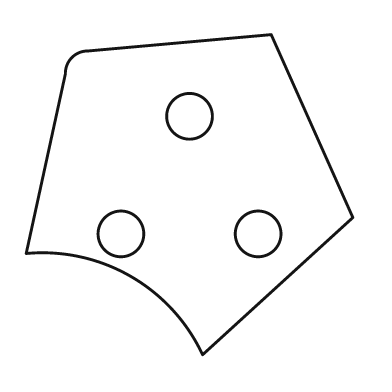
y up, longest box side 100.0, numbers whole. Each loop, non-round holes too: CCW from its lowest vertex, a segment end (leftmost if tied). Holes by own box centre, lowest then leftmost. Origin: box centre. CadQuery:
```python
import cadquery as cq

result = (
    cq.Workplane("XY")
    .moveTo(4.0, -49.0)
    .lineTo(50.0, -7.0)
    .lineTo(25.0, 49.0)
    .lineTo(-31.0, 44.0)
    .threePointArc((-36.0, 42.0), (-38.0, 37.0))
    .lineTo(-50.0, -18.0)
    .threePointArc((-18.0, -25.0), (4.0, -49.0))
    .close()
    .moveTo(-21.0, -12.0)
    .circle(7.0)
    .moveTo(21.0, -12.0)
    .circle(7.0)
    .moveTo(0.0, 24.0)
    .circle(7.0)
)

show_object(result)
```